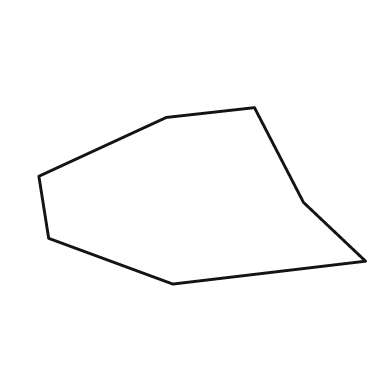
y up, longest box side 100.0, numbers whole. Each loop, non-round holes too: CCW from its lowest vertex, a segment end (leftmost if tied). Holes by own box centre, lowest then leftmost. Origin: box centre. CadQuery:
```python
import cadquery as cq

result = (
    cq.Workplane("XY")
    .moveTo(-9.0, -27.0)
    .lineTo(50.0, -20.0)
    .lineTo(31.0, -2.0)
    .lineTo(16.0, 27.0)
    .lineTo(-11.0, 24.0)
    .lineTo(-50.0, 6.0)
    .lineTo(-47.0, -13.0)
    .close()
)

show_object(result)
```